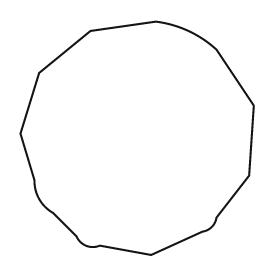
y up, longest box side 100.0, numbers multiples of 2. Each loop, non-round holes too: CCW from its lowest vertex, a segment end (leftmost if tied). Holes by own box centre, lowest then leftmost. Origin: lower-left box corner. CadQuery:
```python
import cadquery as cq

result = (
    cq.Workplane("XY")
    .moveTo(56.0, 0.0)
    .lineTo(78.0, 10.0)
    .threePointArc((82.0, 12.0), (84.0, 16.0))
    .lineTo(98.0, 34.0)
    .lineTo(100.0, 64.0)
    .lineTo(84.0, 88.0)
    .threePointArc((72.0, 96.0), (58.0, 100.0))
    .lineTo(30.0, 96.0)
    .lineTo(8.0, 78.0)
    .lineTo(0.0, 52.0)
    .lineTo(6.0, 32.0)
    .threePointArc((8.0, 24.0), (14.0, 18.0))
    .lineTo(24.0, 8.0)
    .threePointArc((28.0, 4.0), (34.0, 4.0))
    .close()
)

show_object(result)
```